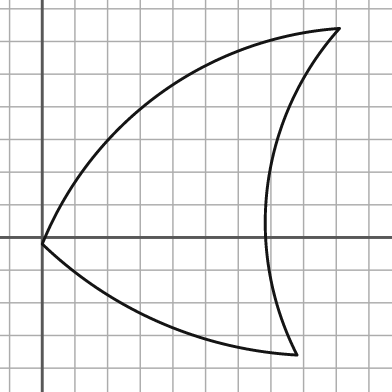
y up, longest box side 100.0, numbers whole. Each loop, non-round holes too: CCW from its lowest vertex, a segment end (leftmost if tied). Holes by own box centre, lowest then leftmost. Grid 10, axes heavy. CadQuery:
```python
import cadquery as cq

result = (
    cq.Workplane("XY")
    .moveTo(78.0, -36.0)
    .threePointArc((69.0, 16.0), (91.0, 64.0))
    .threePointArc((36.0, 44.0), (0.0, -2.0))
    .threePointArc((36.0, -26.0), (78.0, -36.0))
    .close()
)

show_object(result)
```